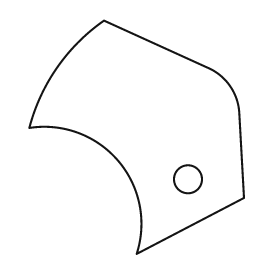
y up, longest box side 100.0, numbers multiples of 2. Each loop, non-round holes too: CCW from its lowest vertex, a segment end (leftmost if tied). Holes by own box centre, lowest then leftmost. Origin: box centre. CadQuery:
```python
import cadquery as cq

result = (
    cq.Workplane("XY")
    .moveTo(0.0, -50.0)
    .lineTo(46.0, -26.0)
    .lineTo(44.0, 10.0)
    .threePointArc((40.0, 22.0), (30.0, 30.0))
    .lineTo(-14.0, 50.0)
    .threePointArc((-34.0, 30.0), (-46.0, 4.0))
    .threePointArc((-8.0, -10.0), (0.0, -50.0))
    .close()
    .moveTo(22.0, -18.0)
    .circle(6.0)
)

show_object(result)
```